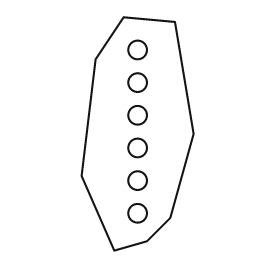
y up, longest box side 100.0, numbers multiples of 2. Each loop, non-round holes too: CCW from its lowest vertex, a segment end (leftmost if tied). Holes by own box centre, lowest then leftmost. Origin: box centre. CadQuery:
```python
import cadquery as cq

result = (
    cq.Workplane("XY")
    .moveTo(-10.0, -50.0)
    .lineTo(4.0, -46.0)
    .lineTo(14.0, -36.0)
    .lineTo(24.0, 0.0)
    .lineTo(16.0, 48.0)
    .lineTo(-6.0, 50.0)
    .lineTo(-18.0, 32.0)
    .lineTo(-24.0, -18.0)
    .close()
    .moveTo(0.0, -34.0)
    .circle(4.0)
    .moveTo(0.0, -20.0)
    .circle(4.0)
    .moveTo(0.0, -6.0)
    .circle(4.0)
    .moveTo(0.0, 8.0)
    .circle(4.0)
    .moveTo(0.0, 22.0)
    .circle(4.0)
    .moveTo(0.0, 36.0)
    .circle(4.0)
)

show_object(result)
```